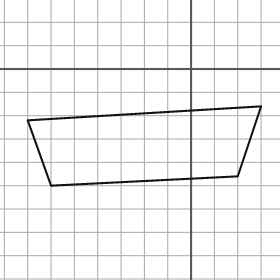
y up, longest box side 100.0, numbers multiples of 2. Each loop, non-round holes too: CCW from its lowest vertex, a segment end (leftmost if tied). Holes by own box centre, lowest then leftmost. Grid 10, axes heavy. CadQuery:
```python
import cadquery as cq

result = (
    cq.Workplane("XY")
    .moveTo(-60.0, -50.0)
    .lineTo(20.0, -46.0)
    .lineTo(30.0, -16.0)
    .lineTo(-70.0, -22.0)
    .close()
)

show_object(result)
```